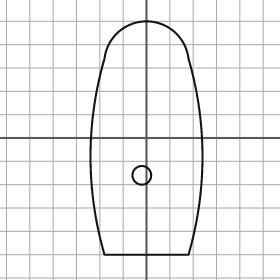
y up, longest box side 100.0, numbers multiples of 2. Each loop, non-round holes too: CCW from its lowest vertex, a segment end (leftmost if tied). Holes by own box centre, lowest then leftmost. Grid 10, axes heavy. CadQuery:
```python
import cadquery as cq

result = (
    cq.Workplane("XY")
    .moveTo(-18.0, -50.0)
    .lineTo(18.0, -50.0)
    .threePointArc((24.0, -8.0), (18.0, 34.0))
    .threePointArc((0.0, 50.0), (-18.0, 34.0))
    .threePointArc((-24.0, -8.0), (-18.0, -50.0))
    .close()
    .moveTo(-2.0, -16.0)
    .circle(4.0)
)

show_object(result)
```